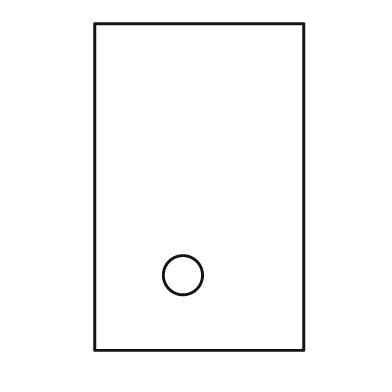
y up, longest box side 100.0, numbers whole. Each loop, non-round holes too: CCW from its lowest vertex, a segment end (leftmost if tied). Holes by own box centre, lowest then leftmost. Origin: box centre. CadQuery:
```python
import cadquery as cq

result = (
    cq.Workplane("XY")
    .moveTo(-32.0, -50.0)
    .lineTo(32.0, -50.0)
    .lineTo(32.0, 50.0)
    .lineTo(-32.0, 50.0)
    .close()
    .moveTo(-5.0, -27.0)
    .circle(6.0)
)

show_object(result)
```